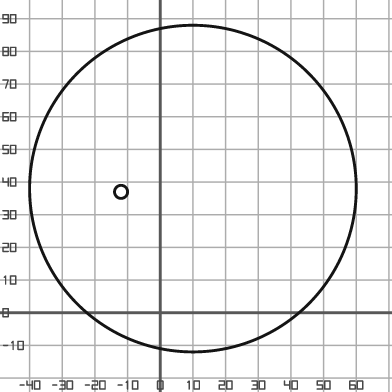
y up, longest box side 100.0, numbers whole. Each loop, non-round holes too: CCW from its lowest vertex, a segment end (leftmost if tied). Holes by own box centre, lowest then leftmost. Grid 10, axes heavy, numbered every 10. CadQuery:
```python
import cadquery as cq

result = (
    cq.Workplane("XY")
    .moveTo(10.0, 38.0)
    .circle(50.0)
    .moveTo(-12.0, 37.0)
    .circle(2.0)
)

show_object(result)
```